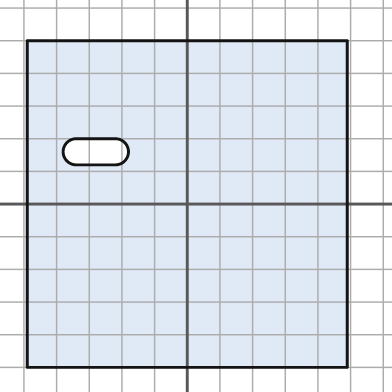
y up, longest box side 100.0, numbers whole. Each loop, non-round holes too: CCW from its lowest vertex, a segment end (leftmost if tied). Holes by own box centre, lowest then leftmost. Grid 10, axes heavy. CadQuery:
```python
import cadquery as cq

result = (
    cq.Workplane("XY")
    .moveTo(-49.0, -50.0)
    .lineTo(49.0, -50.0)
    .lineTo(49.0, 50.0)
    .lineTo(-49.0, 50.0)
    .close()
    .moveTo(-34.0, 12.0)
    .lineTo(-22.0, 12.0)
    .threePointArc((-18.0, 16.0), (-22.0, 20.0))
    .lineTo(-34.0, 20.0)
    .threePointArc((-38.0, 16.0), (-34.0, 12.0))
    .close()
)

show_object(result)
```